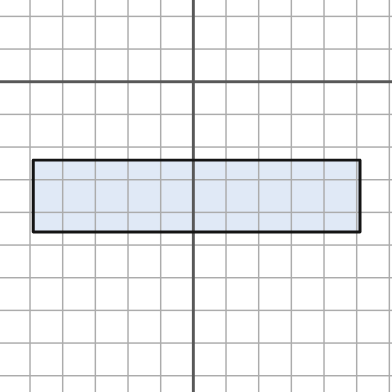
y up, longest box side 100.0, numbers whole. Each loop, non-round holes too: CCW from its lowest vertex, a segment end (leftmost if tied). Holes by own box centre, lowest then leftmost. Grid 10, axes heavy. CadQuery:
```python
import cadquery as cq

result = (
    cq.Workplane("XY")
    .moveTo(-49.0, -46.0)
    .lineTo(51.0, -46.0)
    .lineTo(51.0, -24.0)
    .lineTo(-49.0, -24.0)
    .close()
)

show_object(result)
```